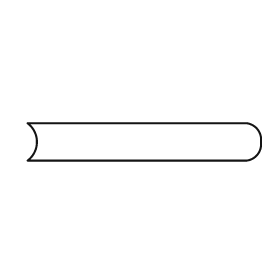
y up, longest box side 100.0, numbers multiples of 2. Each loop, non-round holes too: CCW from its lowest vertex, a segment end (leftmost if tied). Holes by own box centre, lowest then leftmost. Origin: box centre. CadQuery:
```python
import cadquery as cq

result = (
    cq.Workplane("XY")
    .moveTo(-50.0, -8.0)
    .lineTo(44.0, -8.0)
    .threePointArc((48.0, -6.0), (50.0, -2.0))
    .lineTo(50.0, 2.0)
    .threePointArc((48.0, 6.0), (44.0, 8.0))
    .lineTo(-50.0, 8.0)
    .threePointArc((-46.0, 0.0), (-50.0, -8.0))
    .close()
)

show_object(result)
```